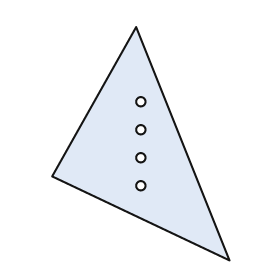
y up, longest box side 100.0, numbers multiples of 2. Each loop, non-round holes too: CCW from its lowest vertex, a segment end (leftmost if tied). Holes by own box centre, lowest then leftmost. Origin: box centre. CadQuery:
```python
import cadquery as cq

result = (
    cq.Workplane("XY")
    .moveTo(38.0, -50.0)
    .lineTo(-2.0, 50.0)
    .lineTo(-38.0, -14.0)
    .close()
    .moveTo(0.0, -18.0)
    .circle(2.0)
    .moveTo(0.0, -6.0)
    .circle(2.0)
    .moveTo(0.0, 6.0)
    .circle(2.0)
    .moveTo(0.0, 18.0)
    .circle(2.0)
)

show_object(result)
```